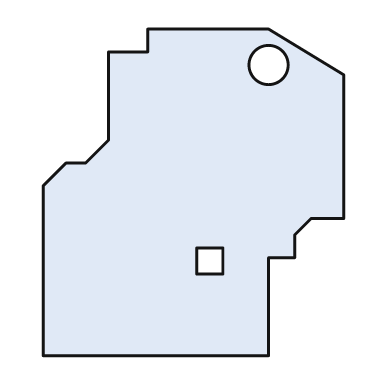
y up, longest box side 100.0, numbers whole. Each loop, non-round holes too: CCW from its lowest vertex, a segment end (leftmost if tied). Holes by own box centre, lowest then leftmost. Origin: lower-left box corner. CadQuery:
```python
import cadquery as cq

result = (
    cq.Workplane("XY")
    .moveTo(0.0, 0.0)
    .lineTo(69.0, 0.0)
    .lineTo(69.0, 30.0)
    .lineTo(77.0, 30.0)
    .lineTo(77.0, 37.0)
    .lineTo(82.0, 42.0)
    .lineTo(92.0, 42.0)
    .lineTo(92.0, 86.0)
    .lineTo(69.0, 100.0)
    .lineTo(32.0, 100.0)
    .lineTo(32.0, 93.0)
    .lineTo(20.0, 93.0)
    .lineTo(20.0, 66.0)
    .lineTo(13.0, 59.0)
    .lineTo(7.0, 59.0)
    .lineTo(0.0, 52.0)
    .close()
    .moveTo(47.0, 25.0)
    .lineTo(55.0, 25.0)
    .lineTo(55.0, 33.0)
    .lineTo(47.0, 33.0)
    .close()
    .moveTo(69.0, 89.0)
    .circle(6.0)
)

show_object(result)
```